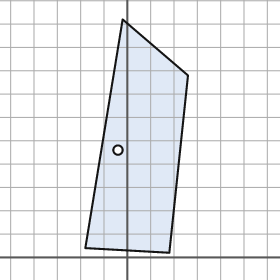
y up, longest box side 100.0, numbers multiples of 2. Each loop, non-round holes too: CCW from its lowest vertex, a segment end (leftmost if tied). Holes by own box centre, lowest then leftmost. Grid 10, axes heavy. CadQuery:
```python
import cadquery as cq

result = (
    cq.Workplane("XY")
    .moveTo(18.0, 2.0)
    .lineTo(26.0, 78.0)
    .lineTo(-2.0, 102.0)
    .lineTo(-18.0, 4.0)
    .close()
    .moveTo(-4.0, 46.0)
    .circle(2.0)
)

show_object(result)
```